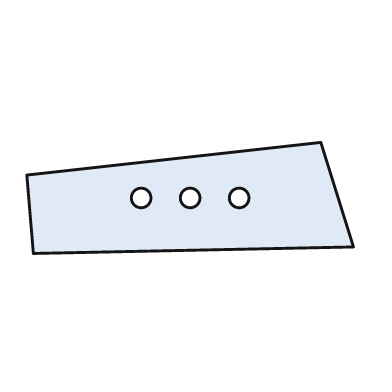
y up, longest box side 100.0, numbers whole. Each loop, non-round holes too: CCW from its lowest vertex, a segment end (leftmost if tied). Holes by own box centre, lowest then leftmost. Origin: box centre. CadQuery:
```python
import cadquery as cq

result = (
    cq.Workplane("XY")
    .moveTo(-48.0, -17.0)
    .lineTo(50.0, -15.0)
    .lineTo(40.0, 17.0)
    .lineTo(-50.0, 7.0)
    .close()
    .moveTo(-15.0, 0.0)
    .circle(3.0)
    .moveTo(0.0, 0.0)
    .circle(3.0)
    .moveTo(15.0, 0.0)
    .circle(3.0)
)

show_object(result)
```